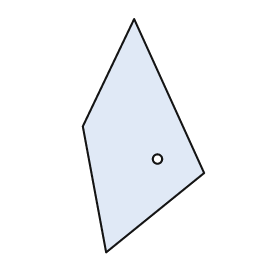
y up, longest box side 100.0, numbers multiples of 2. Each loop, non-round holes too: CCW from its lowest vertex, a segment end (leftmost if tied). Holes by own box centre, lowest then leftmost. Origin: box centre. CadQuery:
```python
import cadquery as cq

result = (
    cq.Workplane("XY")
    .moveTo(-16.0, -50.0)
    .lineTo(26.0, -16.0)
    .lineTo(-4.0, 50.0)
    .lineTo(-26.0, 4.0)
    .close()
    .moveTo(6.0, -10.0)
    .circle(2.0)
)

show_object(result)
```